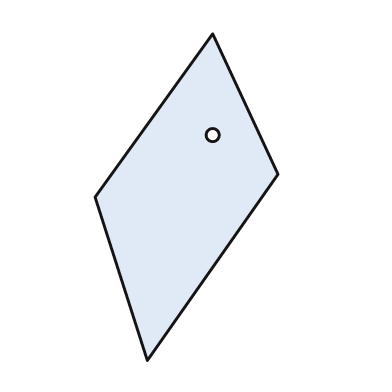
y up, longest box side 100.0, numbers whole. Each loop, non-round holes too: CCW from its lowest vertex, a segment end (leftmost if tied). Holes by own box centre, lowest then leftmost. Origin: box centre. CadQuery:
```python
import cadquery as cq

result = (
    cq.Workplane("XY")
    .moveTo(-12.0, -50.0)
    .lineTo(28.0, 7.0)
    .lineTo(8.0, 50.0)
    .lineTo(-28.0, 0.0)
    .close()
    .moveTo(8.0, 19.0)
    .circle(2.0)
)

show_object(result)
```